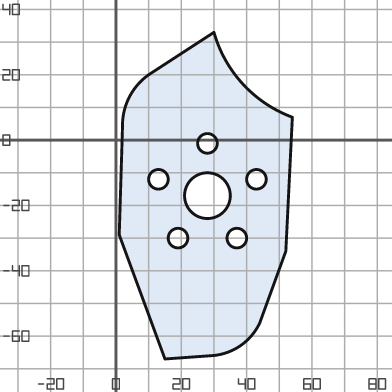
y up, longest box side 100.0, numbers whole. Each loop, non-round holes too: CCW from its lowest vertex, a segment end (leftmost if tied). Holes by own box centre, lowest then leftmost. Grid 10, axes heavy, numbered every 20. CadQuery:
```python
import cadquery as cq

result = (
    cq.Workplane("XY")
    .moveTo(15.0, -67.0)
    .lineTo(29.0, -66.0)
    .threePointArc((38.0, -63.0), (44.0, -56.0))
    .lineTo(52.0, -34.0)
    .lineTo(54.0, 7.0)
    .threePointArc((39.0, 17.0), (30.0, 33.0))
    .lineTo(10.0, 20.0)
    .threePointArc((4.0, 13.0), (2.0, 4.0))
    .lineTo(1.0, -29.0)
    .close()
    .moveTo(19.0, -30.0)
    .circle(3.0)
    .moveTo(37.0, -30.0)
    .circle(3.0)
    .moveTo(28.0, -17.0)
    .circle(7.0)
    .moveTo(13.0, -12.0)
    .circle(3.0)
    .moveTo(43.0, -12.0)
    .circle(3.0)
    .moveTo(28.0, -1.0)
    .circle(3.0)
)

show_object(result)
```